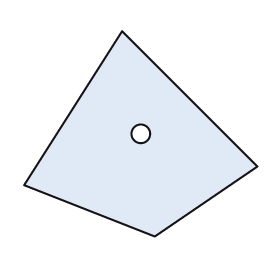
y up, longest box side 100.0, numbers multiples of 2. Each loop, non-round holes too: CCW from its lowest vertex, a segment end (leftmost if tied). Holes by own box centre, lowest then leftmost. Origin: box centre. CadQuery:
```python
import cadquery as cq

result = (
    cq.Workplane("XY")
    .moveTo(6.0, -44.0)
    .lineTo(50.0, -14.0)
    .lineTo(-8.0, 44.0)
    .lineTo(-50.0, -22.0)
    .close()
    .moveTo(0.0, 0.0)
    .circle(4.0)
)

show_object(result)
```